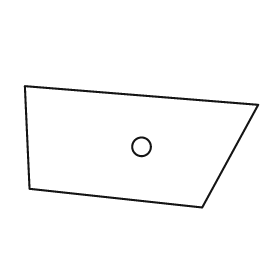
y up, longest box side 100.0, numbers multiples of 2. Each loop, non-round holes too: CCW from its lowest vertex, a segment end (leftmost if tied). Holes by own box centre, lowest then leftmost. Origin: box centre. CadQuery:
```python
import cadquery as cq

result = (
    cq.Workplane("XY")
    .moveTo(26.0, -26.0)
    .lineTo(50.0, 18.0)
    .lineTo(-50.0, 26.0)
    .lineTo(-48.0, -18.0)
    .close()
    .moveTo(0.0, 0.0)
    .circle(4.0)
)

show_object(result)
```